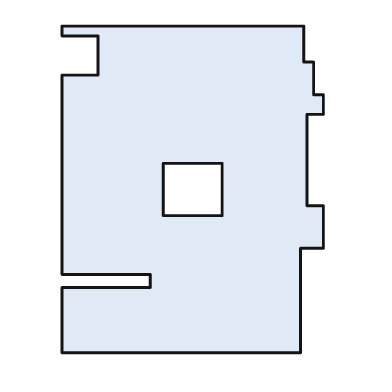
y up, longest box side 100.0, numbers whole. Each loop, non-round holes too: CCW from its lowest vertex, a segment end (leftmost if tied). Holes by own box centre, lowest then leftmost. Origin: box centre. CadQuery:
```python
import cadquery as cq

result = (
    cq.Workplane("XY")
    .moveTo(-40.0, -50.0)
    .lineTo(33.0, -50.0)
    .lineTo(33.0, -18.0)
    .lineTo(40.0, -18.0)
    .lineTo(40.0, -5.0)
    .lineTo(35.0, -5.0)
    .lineTo(35.0, 23.0)
    .lineTo(40.0, 23.0)
    .lineTo(40.0, 29.0)
    .lineTo(37.0, 29.0)
    .lineTo(37.0, 39.0)
    .lineTo(34.0, 39.0)
    .lineTo(34.0, 50.0)
    .lineTo(-40.0, 50.0)
    .lineTo(-40.0, 47.0)
    .lineTo(-29.0, 47.0)
    .lineTo(-29.0, 35.0)
    .lineTo(-40.0, 35.0)
    .lineTo(-40.0, -26.0)
    .lineTo(-13.0, -26.0)
    .lineTo(-13.0, -30.0)
    .lineTo(-40.0, -30.0)
    .close()
    .moveTo(-9.0, -8.0)
    .lineTo(9.0, -8.0)
    .lineTo(9.0, 8.0)
    .lineTo(-9.0, 8.0)
    .close()
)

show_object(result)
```